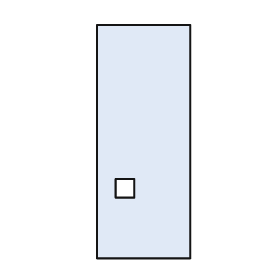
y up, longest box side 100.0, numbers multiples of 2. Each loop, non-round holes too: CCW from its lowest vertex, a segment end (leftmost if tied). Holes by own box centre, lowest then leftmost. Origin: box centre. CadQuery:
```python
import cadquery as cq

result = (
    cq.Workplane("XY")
    .moveTo(-20.0, -50.0)
    .lineTo(20.0, -50.0)
    .lineTo(20.0, 50.0)
    .lineTo(-20.0, 50.0)
    .close()
    .moveTo(-12.0, -24.0)
    .lineTo(-4.0, -24.0)
    .lineTo(-4.0, -16.0)
    .lineTo(-12.0, -16.0)
    .close()
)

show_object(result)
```